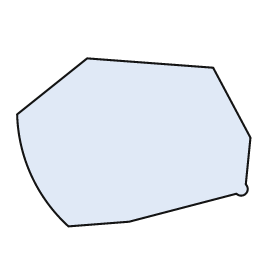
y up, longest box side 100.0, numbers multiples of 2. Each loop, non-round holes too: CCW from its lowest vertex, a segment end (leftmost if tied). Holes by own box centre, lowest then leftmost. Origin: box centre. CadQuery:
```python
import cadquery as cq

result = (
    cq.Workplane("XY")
    .moveTo(-28.0, -36.0)
    .lineTo(-2.0, -34.0)
    .lineTo(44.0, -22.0)
    .threePointArc((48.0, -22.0), (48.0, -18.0))
    .lineTo(50.0, 2.0)
    .lineTo(34.0, 32.0)
    .lineTo(-20.0, 36.0)
    .lineTo(-50.0, 12.0)
    .threePointArc((-44.0, -14.0), (-28.0, -36.0))
    .close()
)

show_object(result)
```